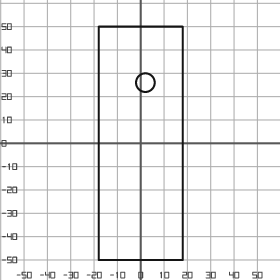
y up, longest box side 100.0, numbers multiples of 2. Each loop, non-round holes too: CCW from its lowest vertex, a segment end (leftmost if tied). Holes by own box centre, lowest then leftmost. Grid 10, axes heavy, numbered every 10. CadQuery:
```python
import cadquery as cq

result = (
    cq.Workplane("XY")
    .moveTo(-18.0, -50.0)
    .lineTo(18.0, -50.0)
    .lineTo(18.0, 50.0)
    .lineTo(-18.0, 50.0)
    .close()
    .moveTo(2.0, 26.0)
    .circle(4.0)
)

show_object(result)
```